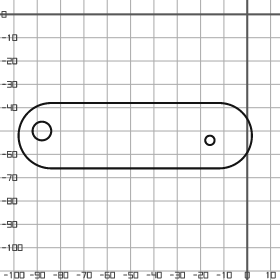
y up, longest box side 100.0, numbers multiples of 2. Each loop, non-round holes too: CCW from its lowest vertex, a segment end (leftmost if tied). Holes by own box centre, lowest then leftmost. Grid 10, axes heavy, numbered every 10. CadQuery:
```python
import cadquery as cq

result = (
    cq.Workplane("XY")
    .moveTo(-84.0, -66.0)
    .lineTo(-12.0, -66.0)
    .threePointArc((2.0, -52.0), (-12.0, -38.0))
    .lineTo(-84.0, -38.0)
    .threePointArc((-98.0, -52.0), (-84.0, -66.0))
    .close()
    .moveTo(-16.0, -54.0)
    .circle(2.0)
    .moveTo(-88.0, -50.0)
    .circle(4.0)
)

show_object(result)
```